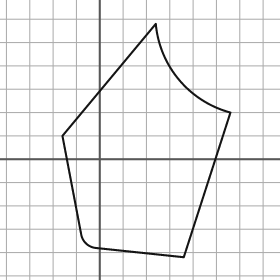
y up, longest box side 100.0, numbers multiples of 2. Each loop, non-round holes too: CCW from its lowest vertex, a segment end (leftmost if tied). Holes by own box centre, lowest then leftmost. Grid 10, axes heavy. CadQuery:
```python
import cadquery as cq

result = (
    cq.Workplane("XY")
    .moveTo(36.0, -42.0)
    .lineTo(56.0, 20.0)
    .threePointArc((34.0, 34.0), (24.0, 58.0))
    .lineTo(-16.0, 10.0)
    .lineTo(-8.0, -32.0)
    .threePointArc((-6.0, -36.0), (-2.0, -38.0))
    .close()
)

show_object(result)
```